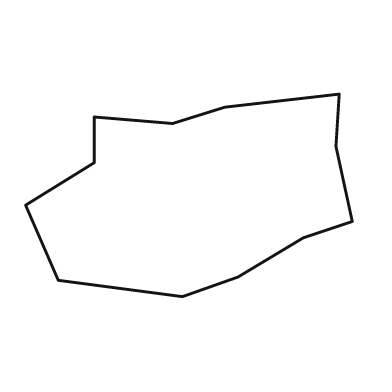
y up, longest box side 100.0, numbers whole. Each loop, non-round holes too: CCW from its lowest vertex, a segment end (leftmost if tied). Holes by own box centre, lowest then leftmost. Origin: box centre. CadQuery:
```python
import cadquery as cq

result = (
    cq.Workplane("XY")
    .moveTo(-2.0, -31.0)
    .lineTo(15.0, -25.0)
    .lineTo(35.0, -13.0)
    .lineTo(50.0, -8.0)
    .lineTo(45.0, 15.0)
    .lineTo(46.0, 31.0)
    .lineTo(11.0, 27.0)
    .lineTo(-5.0, 22.0)
    .lineTo(-29.0, 24.0)
    .lineTo(-29.0, 10.0)
    .lineTo(-50.0, -3.0)
    .lineTo(-40.0, -26.0)
    .close()
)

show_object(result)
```